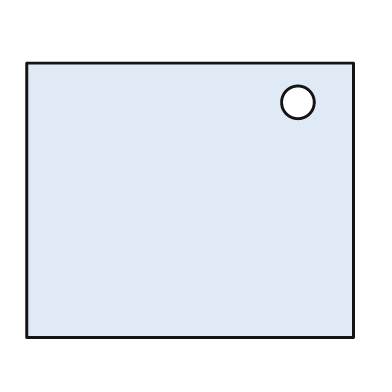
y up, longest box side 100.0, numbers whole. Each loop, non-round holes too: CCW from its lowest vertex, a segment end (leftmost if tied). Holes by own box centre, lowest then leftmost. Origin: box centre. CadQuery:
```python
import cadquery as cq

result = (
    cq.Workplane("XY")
    .moveTo(-50.0, -42.0)
    .lineTo(50.0, -42.0)
    .lineTo(50.0, 42.0)
    .lineTo(-50.0, 42.0)
    .close()
    .moveTo(33.0, 30.0)
    .circle(5.0)
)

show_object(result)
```